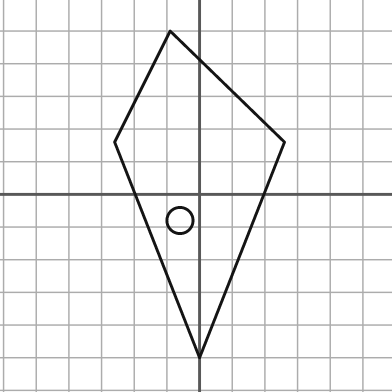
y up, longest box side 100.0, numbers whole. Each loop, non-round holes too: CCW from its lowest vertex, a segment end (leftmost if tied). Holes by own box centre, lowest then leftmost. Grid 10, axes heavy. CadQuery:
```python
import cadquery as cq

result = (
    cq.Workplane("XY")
    .moveTo(0.0, -50.0)
    .lineTo(26.0, 16.0)
    .lineTo(-9.0, 50.0)
    .lineTo(-26.0, 16.0)
    .close()
    .moveTo(-6.0, -8.0)
    .circle(4.0)
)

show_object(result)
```